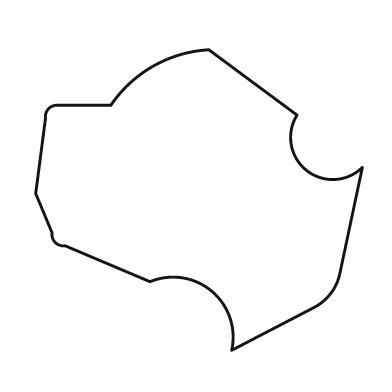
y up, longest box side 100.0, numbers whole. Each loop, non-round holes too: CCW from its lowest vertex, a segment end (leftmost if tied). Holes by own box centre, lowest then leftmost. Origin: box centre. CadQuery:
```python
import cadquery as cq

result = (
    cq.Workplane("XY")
    .moveTo(10.0, -46.0)
    .lineTo(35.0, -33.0)
    .threePointArc((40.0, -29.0), (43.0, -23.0))
    .lineTo(50.0, 10.0)
    .threePointArc((33.0, 9.0), (30.0, 26.0))
    .lineTo(3.0, 46.0)
    .threePointArc((-14.0, 41.0), (-27.0, 29.0))
    .lineTo(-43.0, 29.0)
    .threePointArc((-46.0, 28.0), (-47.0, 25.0))
    .lineTo(-50.0, 2.0)
    .lineTo(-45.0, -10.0)
    .threePointArc((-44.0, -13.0), (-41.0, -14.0))
    .lineTo(-15.0, -25.0)
    .threePointArc((4.0, -28.0), (10.0, -46.0))
    .close()
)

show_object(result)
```